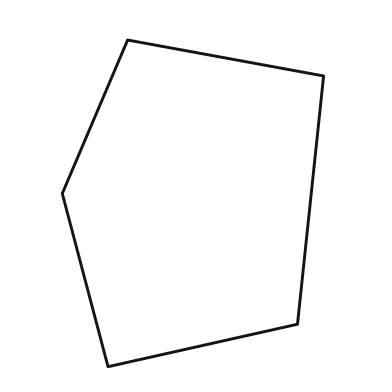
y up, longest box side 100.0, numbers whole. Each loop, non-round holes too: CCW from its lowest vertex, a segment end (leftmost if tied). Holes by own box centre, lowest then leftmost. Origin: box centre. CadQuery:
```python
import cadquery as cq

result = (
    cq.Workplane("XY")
    .moveTo(-26.0, -50.0)
    .lineTo(32.0, -37.0)
    .lineTo(40.0, 39.0)
    .lineTo(-20.0, 50.0)
    .lineTo(-40.0, 3.0)
    .close()
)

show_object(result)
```